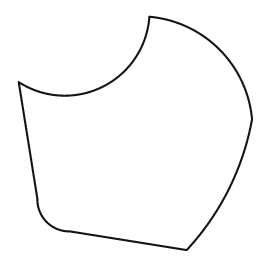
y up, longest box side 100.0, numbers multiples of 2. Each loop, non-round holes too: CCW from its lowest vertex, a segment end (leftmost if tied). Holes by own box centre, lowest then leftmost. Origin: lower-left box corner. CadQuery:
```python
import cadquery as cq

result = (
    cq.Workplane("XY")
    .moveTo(72.0, 0.0)
    .threePointArc((90.0, 26.0), (100.0, 56.0))
    .threePointArc((86.0, 86.0), (56.0, 100.0))
    .threePointArc((36.0, 70.0), (0.0, 72.0))
    .lineTo(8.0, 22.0)
    .threePointArc((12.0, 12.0), (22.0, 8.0))
    .close()
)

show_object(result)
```